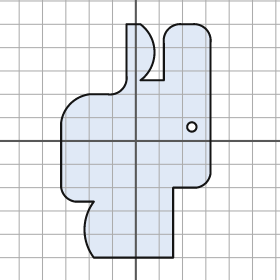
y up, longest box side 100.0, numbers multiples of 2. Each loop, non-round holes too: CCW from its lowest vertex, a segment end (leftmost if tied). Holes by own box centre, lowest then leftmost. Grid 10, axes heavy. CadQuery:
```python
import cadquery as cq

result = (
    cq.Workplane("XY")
    .moveTo(-18.0, -50.0)
    .lineTo(16.0, -50.0)
    .lineTo(16.0, -20.0)
    .lineTo(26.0, -20.0)
    .threePointArc((30.0, -18.0), (32.0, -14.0))
    .lineTo(32.0, 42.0)
    .threePointArc((30.0, 48.0), (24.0, 50.0))
    .lineTo(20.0, 50.0)
    .threePointArc((14.0, 48.0), (12.0, 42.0))
    .lineTo(12.0, 26.0)
    .lineTo(2.0, 26.0)
    .threePointArc((8.0, 38.0), (2.0, 50.0))
    .lineTo(-4.0, 50.0)
    .lineTo(-4.0, 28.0)
    .threePointArc((-6.0, 22.0), (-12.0, 20.0))
    .lineTo(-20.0, 20.0)
    .threePointArc((-28.0, 16.0), (-32.0, 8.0))
    .lineTo(-32.0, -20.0)
    .threePointArc((-30.0, -24.0), (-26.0, -26.0))
    .lineTo(-18.0, -26.0)
    .threePointArc((-22.0, -38.0), (-18.0, -50.0))
    .close()
    .moveTo(24.0, 6.0)
    .circle(2.0)
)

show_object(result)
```